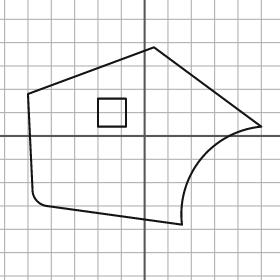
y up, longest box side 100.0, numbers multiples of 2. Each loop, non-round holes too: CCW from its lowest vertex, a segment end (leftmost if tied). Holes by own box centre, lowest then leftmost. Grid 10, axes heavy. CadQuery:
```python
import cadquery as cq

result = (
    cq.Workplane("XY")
    .moveTo(16.0, -38.0)
    .threePointArc((24.0, -10.0), (50.0, 4.0))
    .lineTo(4.0, 38.0)
    .lineTo(-50.0, 18.0)
    .lineTo(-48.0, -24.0)
    .threePointArc((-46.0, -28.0), (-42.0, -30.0))
    .close()
    .moveTo(-20.0, 4.0)
    .lineTo(-8.0, 4.0)
    .lineTo(-8.0, 16.0)
    .lineTo(-20.0, 16.0)
    .close()
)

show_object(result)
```